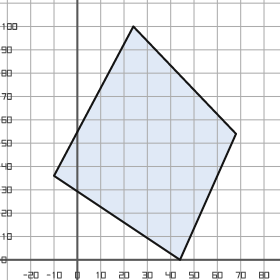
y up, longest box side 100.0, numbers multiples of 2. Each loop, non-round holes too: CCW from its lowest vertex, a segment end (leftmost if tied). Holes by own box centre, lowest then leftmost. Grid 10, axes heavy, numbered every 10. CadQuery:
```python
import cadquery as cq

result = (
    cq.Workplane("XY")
    .moveTo(44.0, 0.0)
    .lineTo(68.0, 54.0)
    .lineTo(24.0, 100.0)
    .lineTo(-10.0, 36.0)
    .close()
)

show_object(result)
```